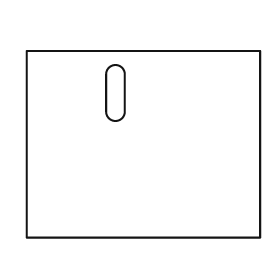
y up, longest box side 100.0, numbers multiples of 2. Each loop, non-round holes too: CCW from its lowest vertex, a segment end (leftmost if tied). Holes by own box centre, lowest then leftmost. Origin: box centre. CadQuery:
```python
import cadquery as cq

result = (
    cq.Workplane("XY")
    .moveTo(-50.0, -40.0)
    .lineTo(50.0, -40.0)
    .lineTo(50.0, 40.0)
    .lineTo(-50.0, 40.0)
    .close()
    .moveTo(-16.0, 14.0)
    .threePointArc((-12.0, 10.0), (-8.0, 14.0))
    .lineTo(-8.0, 30.0)
    .threePointArc((-12.0, 34.0), (-16.0, 30.0))
    .close()
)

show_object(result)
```